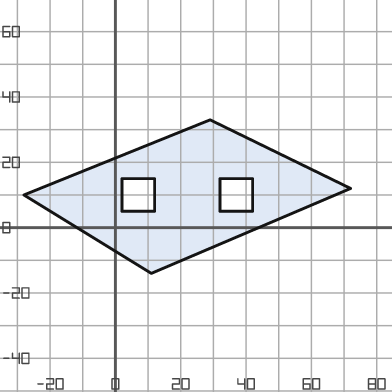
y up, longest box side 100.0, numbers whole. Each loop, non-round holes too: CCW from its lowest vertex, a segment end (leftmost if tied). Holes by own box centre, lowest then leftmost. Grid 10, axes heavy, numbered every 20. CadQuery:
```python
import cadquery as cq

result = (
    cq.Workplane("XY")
    .moveTo(11.0, -14.0)
    .lineTo(72.0, 12.0)
    .lineTo(29.0, 33.0)
    .lineTo(-28.0, 10.0)
    .close()
    .moveTo(2.0, 5.0)
    .lineTo(12.0, 5.0)
    .lineTo(12.0, 15.0)
    .lineTo(2.0, 15.0)
    .close()
    .moveTo(32.0, 5.0)
    .lineTo(42.0, 5.0)
    .lineTo(42.0, 15.0)
    .lineTo(32.0, 15.0)
    .close()
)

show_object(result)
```